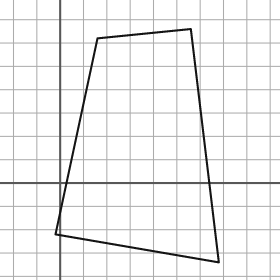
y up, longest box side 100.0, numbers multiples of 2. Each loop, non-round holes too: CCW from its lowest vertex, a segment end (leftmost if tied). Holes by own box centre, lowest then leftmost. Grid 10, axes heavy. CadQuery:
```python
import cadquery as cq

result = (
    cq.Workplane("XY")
    .moveTo(68.0, -34.0)
    .lineTo(56.0, 66.0)
    .lineTo(16.0, 62.0)
    .lineTo(-2.0, -22.0)
    .close()
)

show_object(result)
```